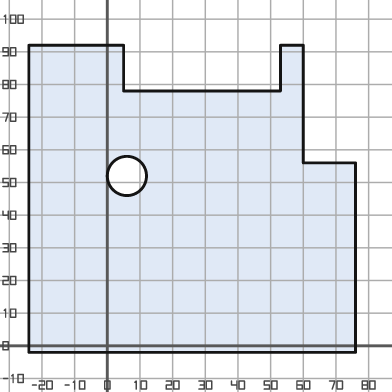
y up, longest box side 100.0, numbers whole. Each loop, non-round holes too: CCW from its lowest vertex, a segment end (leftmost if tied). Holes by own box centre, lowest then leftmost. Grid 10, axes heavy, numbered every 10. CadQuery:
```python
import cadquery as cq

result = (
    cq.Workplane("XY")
    .moveTo(-24.0, -2.0)
    .lineTo(76.0, -2.0)
    .lineTo(76.0, 56.0)
    .lineTo(60.0, 56.0)
    .lineTo(60.0, 92.0)
    .lineTo(53.0, 92.0)
    .lineTo(53.0, 78.0)
    .lineTo(5.0, 78.0)
    .lineTo(5.0, 92.0)
    .lineTo(-24.0, 92.0)
    .close()
    .moveTo(6.0, 52.0)
    .circle(6.0)
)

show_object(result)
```